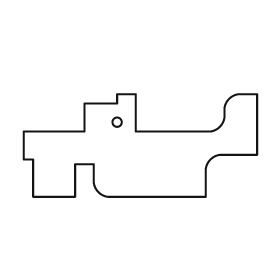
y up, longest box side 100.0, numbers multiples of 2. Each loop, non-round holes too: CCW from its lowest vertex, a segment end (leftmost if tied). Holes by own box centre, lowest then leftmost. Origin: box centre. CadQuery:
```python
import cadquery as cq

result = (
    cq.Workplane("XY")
    .moveTo(-46.0, -22.0)
    .lineTo(-28.0, -22.0)
    .lineTo(-28.0, -8.0)
    .lineTo(-20.0, -8.0)
    .lineTo(-20.0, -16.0)
    .threePointArc((-18.0, -20.0), (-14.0, -22.0))
    .lineTo(28.0, -22.0)
    .lineTo(28.0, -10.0)
    .threePointArc((30.0, -6.0), (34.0, -4.0))
    .lineTo(50.0, -4.0)
    .lineTo(50.0, 22.0)
    .lineTo(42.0, 22.0)
    .threePointArc((38.0, 20.0), (36.0, 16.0))
    .lineTo(36.0, 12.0)
    .threePointArc((34.0, 8.0), (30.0, 6.0))
    .lineTo(-2.0, 6.0)
    .lineTo(-2.0, 22.0)
    .lineTo(-10.0, 22.0)
    .lineTo(-10.0, 18.0)
    .lineTo(-24.0, 18.0)
    .lineTo(-24.0, 6.0)
    .lineTo(-50.0, 6.0)
    .lineTo(-50.0, -6.0)
    .lineTo(-46.0, -6.0)
    .close()
    .moveTo(-10.0, 10.0)
    .circle(2.0)
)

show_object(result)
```